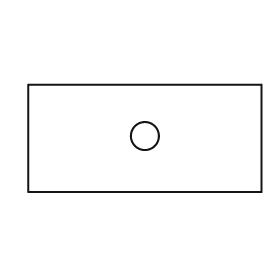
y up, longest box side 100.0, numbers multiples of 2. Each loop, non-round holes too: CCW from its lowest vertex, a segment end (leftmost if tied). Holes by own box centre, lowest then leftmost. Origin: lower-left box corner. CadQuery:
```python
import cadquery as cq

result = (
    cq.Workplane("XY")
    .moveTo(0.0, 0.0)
    .lineTo(100.0, 0.0)
    .lineTo(100.0, 46.0)
    .lineTo(0.0, 46.0)
    .close()
    .moveTo(50.0, 24.0)
    .circle(6.0)
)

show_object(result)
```